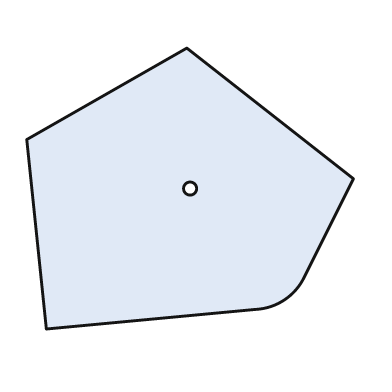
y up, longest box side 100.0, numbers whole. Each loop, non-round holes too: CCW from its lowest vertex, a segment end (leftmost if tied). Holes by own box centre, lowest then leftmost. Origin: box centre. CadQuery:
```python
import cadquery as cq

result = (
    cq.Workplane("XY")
    .moveTo(-44.0, -43.0)
    .lineTo(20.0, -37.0)
    .threePointArc((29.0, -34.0), (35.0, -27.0))
    .lineTo(50.0, 3.0)
    .lineTo(-1.0, 43.0)
    .lineTo(-50.0, 15.0)
    .close()
    .moveTo(0.0, 0.0)
    .circle(2.0)
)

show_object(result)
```